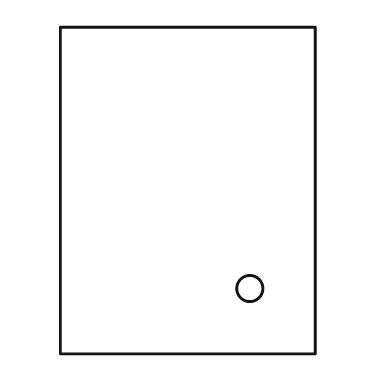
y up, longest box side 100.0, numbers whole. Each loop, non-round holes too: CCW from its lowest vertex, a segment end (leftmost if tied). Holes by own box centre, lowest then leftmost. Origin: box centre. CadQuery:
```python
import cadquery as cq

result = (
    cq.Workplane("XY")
    .moveTo(-39.0, -50.0)
    .lineTo(39.0, -50.0)
    .lineTo(39.0, 50.0)
    .lineTo(-39.0, 50.0)
    .close()
    .moveTo(19.0, -30.0)
    .circle(4.0)
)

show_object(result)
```